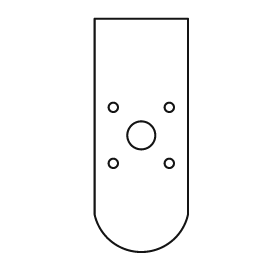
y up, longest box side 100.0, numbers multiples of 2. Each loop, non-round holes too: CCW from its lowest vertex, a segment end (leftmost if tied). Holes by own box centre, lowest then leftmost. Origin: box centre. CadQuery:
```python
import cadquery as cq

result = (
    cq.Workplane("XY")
    .moveTo(-20.0, -34.0)
    .threePointArc((0.0, -50.0), (20.0, -34.0))
    .lineTo(20.0, 50.0)
    .lineTo(-20.0, 50.0)
    .close()
    .moveTo(-12.0, -12.0)
    .circle(2.0)
    .moveTo(12.0, -12.0)
    .circle(2.0)
    .moveTo(0.0, 0.0)
    .circle(6.0)
    .moveTo(-12.0, 12.0)
    .circle(2.0)
    .moveTo(12.0, 12.0)
    .circle(2.0)
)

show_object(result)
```